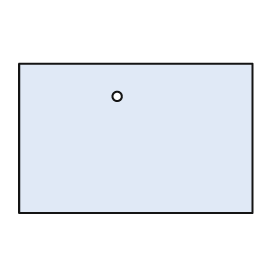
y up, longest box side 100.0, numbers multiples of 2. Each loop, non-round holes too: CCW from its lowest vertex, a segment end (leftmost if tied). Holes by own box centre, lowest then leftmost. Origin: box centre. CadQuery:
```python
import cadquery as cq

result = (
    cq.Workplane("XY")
    .moveTo(-50.0, -32.0)
    .lineTo(50.0, -32.0)
    .lineTo(50.0, 32.0)
    .lineTo(-50.0, 32.0)
    .close()
    .moveTo(-8.0, 18.0)
    .circle(2.0)
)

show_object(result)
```